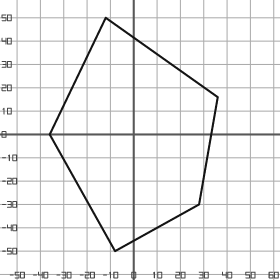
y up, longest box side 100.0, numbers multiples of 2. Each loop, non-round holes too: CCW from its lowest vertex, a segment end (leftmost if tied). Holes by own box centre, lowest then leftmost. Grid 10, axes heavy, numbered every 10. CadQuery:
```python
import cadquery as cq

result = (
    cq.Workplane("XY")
    .moveTo(-8.0, -50.0)
    .lineTo(28.0, -30.0)
    .lineTo(36.0, 16.0)
    .lineTo(-12.0, 50.0)
    .lineTo(-36.0, 0.0)
    .close()
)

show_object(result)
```